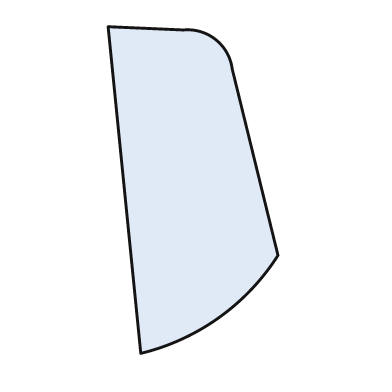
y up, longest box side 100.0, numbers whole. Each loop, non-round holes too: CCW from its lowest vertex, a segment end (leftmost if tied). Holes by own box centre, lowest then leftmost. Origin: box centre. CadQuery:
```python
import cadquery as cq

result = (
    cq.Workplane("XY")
    .moveTo(-16.0, -50.0)
    .threePointArc((8.0, -39.0), (26.0, -20.0))
    .lineTo(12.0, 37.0)
    .threePointArc((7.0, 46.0), (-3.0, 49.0))
    .lineTo(-26.0, 50.0)
    .close()
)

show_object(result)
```